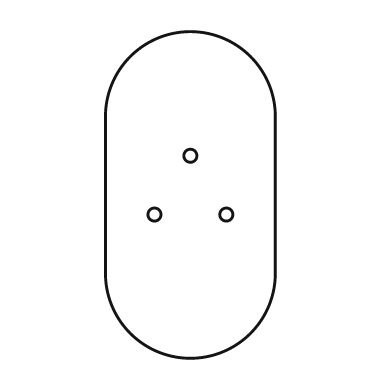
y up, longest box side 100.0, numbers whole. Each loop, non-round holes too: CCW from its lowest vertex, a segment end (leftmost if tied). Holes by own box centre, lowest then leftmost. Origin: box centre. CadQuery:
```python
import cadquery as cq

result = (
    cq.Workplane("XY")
    .moveTo(-26.0, -24.0)
    .threePointArc((0.0, -50.0), (26.0, -24.0))
    .lineTo(26.0, 24.0)
    .threePointArc((0.0, 50.0), (-26.0, 24.0))
    .close()
    .moveTo(-11.0, -6.0)
    .circle(2.0)
    .moveTo(11.0, -6.0)
    .circle(2.0)
    .moveTo(0.0, 12.0)
    .circle(2.0)
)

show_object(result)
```